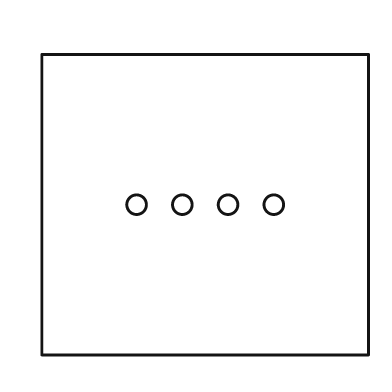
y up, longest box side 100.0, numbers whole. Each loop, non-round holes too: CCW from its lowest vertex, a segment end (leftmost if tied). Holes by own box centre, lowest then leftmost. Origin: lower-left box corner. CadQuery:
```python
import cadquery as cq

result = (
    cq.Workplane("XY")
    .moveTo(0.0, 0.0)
    .lineTo(100.0, 0.0)
    .lineTo(100.0, 92.0)
    .lineTo(0.0, 92.0)
    .close()
    .moveTo(29.0, 46.0)
    .circle(3.0)
    .moveTo(43.0, 46.0)
    .circle(3.0)
    .moveTo(57.0, 46.0)
    .circle(3.0)
    .moveTo(71.0, 46.0)
    .circle(3.0)
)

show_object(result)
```